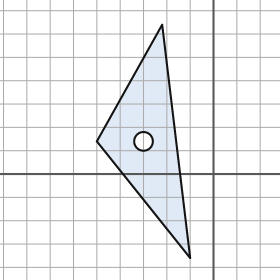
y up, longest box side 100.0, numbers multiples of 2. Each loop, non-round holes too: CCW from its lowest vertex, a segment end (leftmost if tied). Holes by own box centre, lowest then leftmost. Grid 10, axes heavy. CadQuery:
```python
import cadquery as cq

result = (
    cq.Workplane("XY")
    .moveTo(-10.0, -36.0)
    .lineTo(-22.0, 64.0)
    .lineTo(-50.0, 14.0)
    .close()
    .moveTo(-30.0, 14.0)
    .circle(4.0)
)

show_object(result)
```